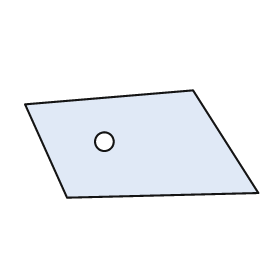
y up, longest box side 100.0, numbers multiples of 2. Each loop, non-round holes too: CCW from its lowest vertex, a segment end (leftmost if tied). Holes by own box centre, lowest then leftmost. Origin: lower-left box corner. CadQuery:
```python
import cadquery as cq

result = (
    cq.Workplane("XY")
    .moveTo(18.0, 0.0)
    .lineTo(100.0, 2.0)
    .lineTo(72.0, 46.0)
    .lineTo(0.0, 40.0)
    .close()
    .moveTo(34.0, 24.0)
    .circle(4.0)
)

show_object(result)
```